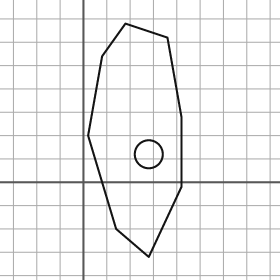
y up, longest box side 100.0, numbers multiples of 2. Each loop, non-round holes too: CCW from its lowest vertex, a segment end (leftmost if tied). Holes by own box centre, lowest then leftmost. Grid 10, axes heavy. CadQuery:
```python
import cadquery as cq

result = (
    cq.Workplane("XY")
    .moveTo(28.0, -32.0)
    .lineTo(42.0, -2.0)
    .lineTo(42.0, 28.0)
    .lineTo(36.0, 62.0)
    .lineTo(18.0, 68.0)
    .lineTo(8.0, 54.0)
    .lineTo(2.0, 20.0)
    .lineTo(14.0, -20.0)
    .close()
    .moveTo(28.0, 12.0)
    .circle(6.0)
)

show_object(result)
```